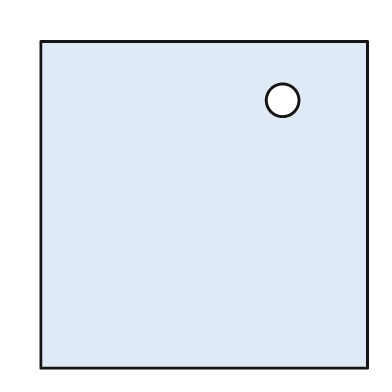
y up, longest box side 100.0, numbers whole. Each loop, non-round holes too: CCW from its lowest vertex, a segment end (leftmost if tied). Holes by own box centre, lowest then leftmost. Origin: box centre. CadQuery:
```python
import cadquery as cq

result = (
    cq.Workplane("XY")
    .moveTo(-50.0, -50.0)
    .lineTo(50.0, -50.0)
    .lineTo(50.0, 50.0)
    .lineTo(-50.0, 50.0)
    .close()
    .moveTo(24.0, 32.0)
    .circle(5.0)
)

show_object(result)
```